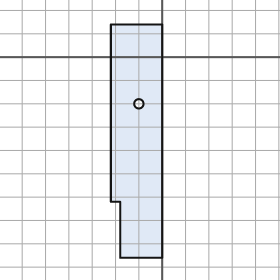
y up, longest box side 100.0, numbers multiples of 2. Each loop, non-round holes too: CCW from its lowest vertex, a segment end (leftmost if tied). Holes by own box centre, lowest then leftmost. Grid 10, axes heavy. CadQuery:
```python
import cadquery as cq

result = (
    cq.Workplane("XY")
    .moveTo(-18.0, -86.0)
    .lineTo(0.0, -86.0)
    .lineTo(0.0, 14.0)
    .lineTo(-22.0, 14.0)
    .lineTo(-22.0, -62.0)
    .lineTo(-18.0, -62.0)
    .close()
    .moveTo(-10.0, -20.0)
    .circle(2.0)
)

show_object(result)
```